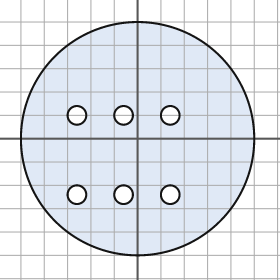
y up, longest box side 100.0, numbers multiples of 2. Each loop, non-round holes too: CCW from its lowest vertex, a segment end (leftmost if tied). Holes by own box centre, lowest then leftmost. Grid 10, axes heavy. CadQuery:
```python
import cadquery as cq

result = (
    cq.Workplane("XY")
    .moveTo(0.0, 0.0)
    .circle(50.0)
    .moveTo(-26.0, -24.0)
    .circle(4.0)
    .moveTo(-6.0, -24.0)
    .circle(4.0)
    .moveTo(14.0, -24.0)
    .circle(4.0)
    .moveTo(-26.0, 10.0)
    .circle(4.0)
    .moveTo(-6.0, 10.0)
    .circle(4.0)
    .moveTo(14.0, 10.0)
    .circle(4.0)
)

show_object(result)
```